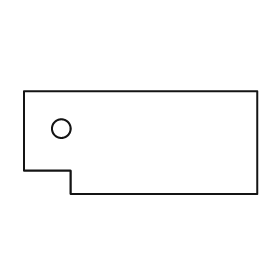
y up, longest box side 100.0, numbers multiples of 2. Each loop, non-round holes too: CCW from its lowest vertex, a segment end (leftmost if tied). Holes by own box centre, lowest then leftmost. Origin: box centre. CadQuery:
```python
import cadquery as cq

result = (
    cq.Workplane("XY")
    .moveTo(-30.0, -22.0)
    .lineTo(50.0, -22.0)
    .lineTo(50.0, 22.0)
    .lineTo(-50.0, 22.0)
    .lineTo(-50.0, -12.0)
    .lineTo(-30.0, -12.0)
    .close()
    .moveTo(-34.0, 6.0)
    .circle(4.0)
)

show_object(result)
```